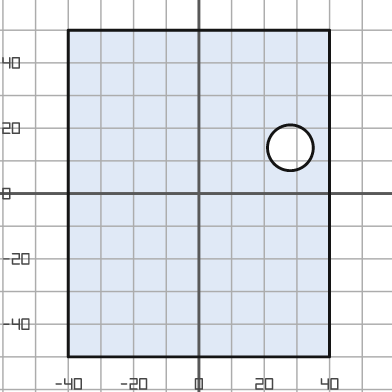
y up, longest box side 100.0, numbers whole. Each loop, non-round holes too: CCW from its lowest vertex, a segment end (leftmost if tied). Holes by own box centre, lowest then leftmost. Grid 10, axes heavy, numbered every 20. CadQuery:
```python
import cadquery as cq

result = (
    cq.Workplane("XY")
    .moveTo(-40.0, -50.0)
    .lineTo(40.0, -50.0)
    .lineTo(40.0, 50.0)
    .lineTo(-40.0, 50.0)
    .close()
    .moveTo(28.0, 14.0)
    .circle(7.0)
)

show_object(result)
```